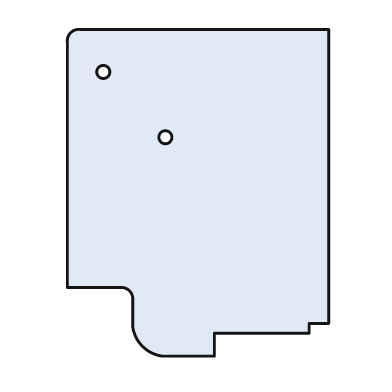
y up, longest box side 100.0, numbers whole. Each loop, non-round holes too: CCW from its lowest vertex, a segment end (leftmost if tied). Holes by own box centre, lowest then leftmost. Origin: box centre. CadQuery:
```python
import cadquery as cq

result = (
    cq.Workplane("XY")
    .moveTo(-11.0, -50.0)
    .lineTo(5.0, -50.0)
    .lineTo(5.0, -43.0)
    .lineTo(34.0, -43.0)
    .lineTo(34.0, -40.0)
    .lineTo(40.0, -40.0)
    .lineTo(40.0, 50.0)
    .lineTo(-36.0, 50.0)
    .threePointArc((-39.0, 49.0), (-40.0, 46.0))
    .lineTo(-40.0, -29.0)
    .lineTo(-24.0, -29.0)
    .threePointArc((-21.0, -30.0), (-20.0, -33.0))
    .lineTo(-20.0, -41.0)
    .threePointArc((-17.0, -47.0), (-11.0, -50.0))
    .close()
    .moveTo(-10.0, 17.0)
    .circle(2.0)
    .moveTo(-29.0, 37.0)
    .circle(2.0)
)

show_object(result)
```